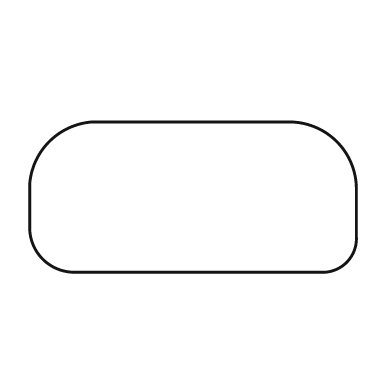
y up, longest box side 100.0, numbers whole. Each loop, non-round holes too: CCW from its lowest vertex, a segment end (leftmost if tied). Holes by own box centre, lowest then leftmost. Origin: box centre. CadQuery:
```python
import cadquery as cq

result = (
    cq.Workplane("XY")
    .moveTo(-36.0, -23.0)
    .lineTo(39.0, -23.0)
    .threePointArc((47.0, -20.0), (50.0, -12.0))
    .lineTo(50.0, 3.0)
    .threePointArc((44.0, 17.0), (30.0, 23.0))
    .lineTo(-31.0, 23.0)
    .threePointArc((-44.0, 17.0), (-50.0, 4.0))
    .lineTo(-50.0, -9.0)
    .threePointArc((-46.0, -19.0), (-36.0, -23.0))
    .close()
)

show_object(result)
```